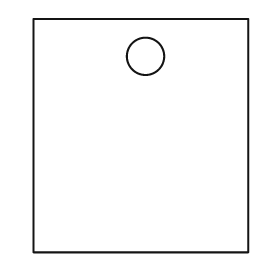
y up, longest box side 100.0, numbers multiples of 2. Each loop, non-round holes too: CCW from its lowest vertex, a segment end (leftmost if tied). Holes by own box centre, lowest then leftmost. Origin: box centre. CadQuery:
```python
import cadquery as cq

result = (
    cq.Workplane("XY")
    .moveTo(-46.0, -50.0)
    .lineTo(46.0, -50.0)
    .lineTo(46.0, 50.0)
    .lineTo(-46.0, 50.0)
    .close()
    .moveTo(2.0, 34.0)
    .circle(8.0)
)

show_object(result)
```